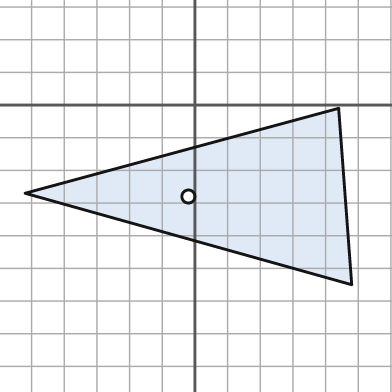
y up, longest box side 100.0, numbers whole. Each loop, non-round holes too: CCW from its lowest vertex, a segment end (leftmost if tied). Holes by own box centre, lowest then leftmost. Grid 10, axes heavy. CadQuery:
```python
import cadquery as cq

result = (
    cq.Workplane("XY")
    .moveTo(48.0, -55.0)
    .lineTo(44.0, -1.0)
    .lineTo(-52.0, -27.0)
    .close()
    .moveTo(-2.0, -28.0)
    .circle(2.0)
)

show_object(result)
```